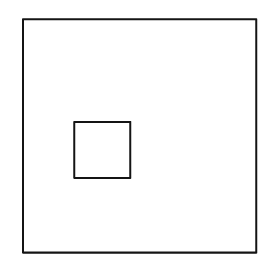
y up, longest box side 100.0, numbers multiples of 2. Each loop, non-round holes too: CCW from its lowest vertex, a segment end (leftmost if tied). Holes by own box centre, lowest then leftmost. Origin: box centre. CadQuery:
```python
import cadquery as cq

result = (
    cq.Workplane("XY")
    .moveTo(-50.0, -50.0)
    .lineTo(50.0, -50.0)
    .lineTo(50.0, 50.0)
    .lineTo(-50.0, 50.0)
    .close()
    .moveTo(-28.0, -18.0)
    .lineTo(-4.0, -18.0)
    .lineTo(-4.0, 6.0)
    .lineTo(-28.0, 6.0)
    .close()
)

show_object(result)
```